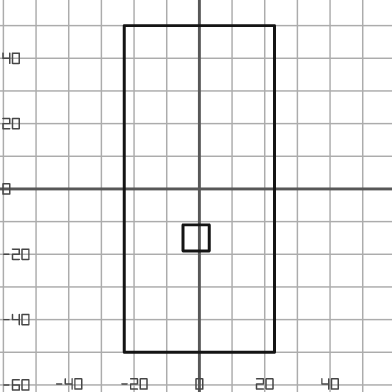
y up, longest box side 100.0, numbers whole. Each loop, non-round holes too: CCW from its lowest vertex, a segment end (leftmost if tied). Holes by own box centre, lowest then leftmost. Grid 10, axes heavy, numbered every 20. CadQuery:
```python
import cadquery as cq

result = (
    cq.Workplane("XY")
    .moveTo(-23.0, -50.0)
    .lineTo(23.0, -50.0)
    .lineTo(23.0, 50.0)
    .lineTo(-23.0, 50.0)
    .close()
    .moveTo(-5.0, -19.0)
    .lineTo(3.0, -19.0)
    .lineTo(3.0, -11.0)
    .lineTo(-5.0, -11.0)
    .close()
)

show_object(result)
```